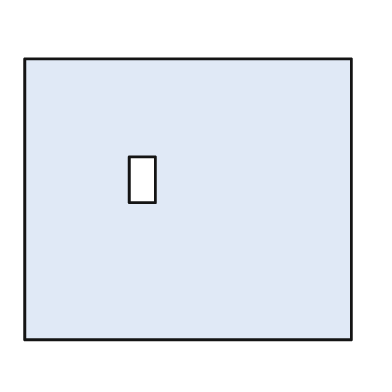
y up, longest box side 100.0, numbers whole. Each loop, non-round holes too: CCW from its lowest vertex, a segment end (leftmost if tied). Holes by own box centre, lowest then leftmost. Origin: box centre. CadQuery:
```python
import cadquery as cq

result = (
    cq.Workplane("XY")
    .moveTo(-50.0, -43.0)
    .lineTo(50.0, -43.0)
    .lineTo(50.0, 43.0)
    .lineTo(-50.0, 43.0)
    .close()
    .moveTo(-18.0, -1.0)
    .lineTo(-10.0, -1.0)
    .lineTo(-10.0, 13.0)
    .lineTo(-18.0, 13.0)
    .close()
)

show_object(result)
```